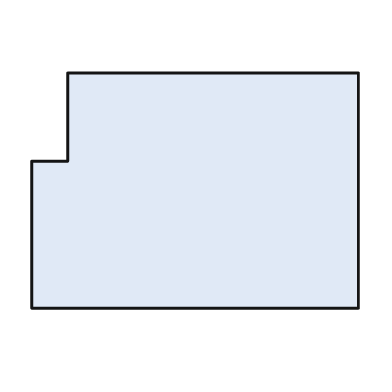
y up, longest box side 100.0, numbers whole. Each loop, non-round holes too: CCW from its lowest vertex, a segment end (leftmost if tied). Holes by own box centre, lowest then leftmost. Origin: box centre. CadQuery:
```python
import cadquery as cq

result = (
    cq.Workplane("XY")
    .moveTo(-50.0, -36.0)
    .lineTo(50.0, -36.0)
    .lineTo(50.0, 36.0)
    .lineTo(-39.0, 36.0)
    .lineTo(-39.0, 9.0)
    .lineTo(-50.0, 9.0)
    .close()
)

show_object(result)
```